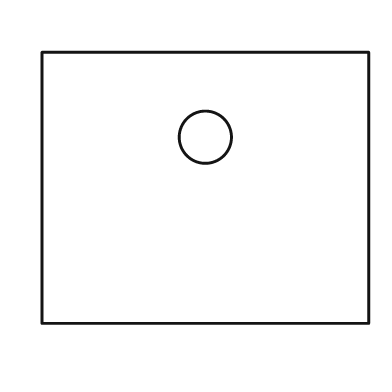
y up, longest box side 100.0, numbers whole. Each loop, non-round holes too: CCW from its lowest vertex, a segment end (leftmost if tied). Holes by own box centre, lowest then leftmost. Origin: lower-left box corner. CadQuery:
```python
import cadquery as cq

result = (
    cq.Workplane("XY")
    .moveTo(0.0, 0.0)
    .lineTo(100.0, 0.0)
    .lineTo(100.0, 83.0)
    .lineTo(0.0, 83.0)
    .close()
    .moveTo(50.0, 57.0)
    .circle(8.0)
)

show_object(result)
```